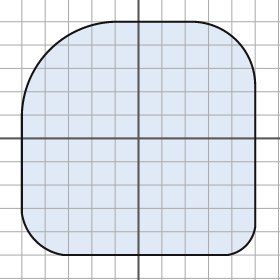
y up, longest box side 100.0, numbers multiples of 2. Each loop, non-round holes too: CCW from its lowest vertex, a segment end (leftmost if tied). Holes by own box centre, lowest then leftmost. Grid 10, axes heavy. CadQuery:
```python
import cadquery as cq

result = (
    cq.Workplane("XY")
    .moveTo(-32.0, -50.0)
    .lineTo(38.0, -50.0)
    .threePointArc((46.0, -46.0), (50.0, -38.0))
    .lineTo(50.0, 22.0)
    .threePointArc((42.0, 42.0), (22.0, 50.0))
    .lineTo(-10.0, 50.0)
    .threePointArc((-38.0, 38.0), (-50.0, 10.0))
    .lineTo(-50.0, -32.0)
    .threePointArc((-44.0, -44.0), (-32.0, -50.0))
    .close()
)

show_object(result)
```